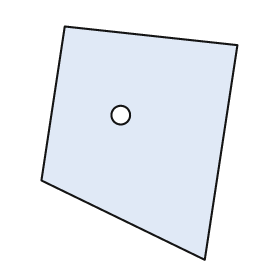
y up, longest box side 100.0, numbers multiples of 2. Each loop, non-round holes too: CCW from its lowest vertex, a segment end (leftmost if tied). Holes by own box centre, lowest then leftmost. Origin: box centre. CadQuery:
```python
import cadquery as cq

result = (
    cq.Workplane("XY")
    .moveTo(28.0, -50.0)
    .lineTo(42.0, 42.0)
    .lineTo(-32.0, 50.0)
    .lineTo(-42.0, -16.0)
    .close()
    .moveTo(-8.0, 12.0)
    .circle(4.0)
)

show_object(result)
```